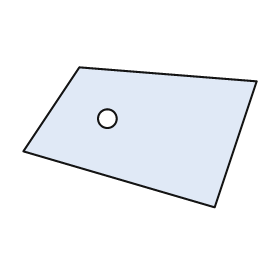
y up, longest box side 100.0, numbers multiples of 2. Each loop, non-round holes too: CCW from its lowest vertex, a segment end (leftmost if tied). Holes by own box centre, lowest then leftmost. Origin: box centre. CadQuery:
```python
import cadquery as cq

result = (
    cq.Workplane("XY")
    .moveTo(32.0, -30.0)
    .lineTo(50.0, 24.0)
    .lineTo(-26.0, 30.0)
    .lineTo(-50.0, -6.0)
    .close()
    .moveTo(-14.0, 8.0)
    .circle(4.0)
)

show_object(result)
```